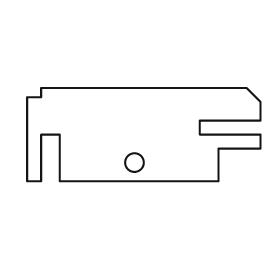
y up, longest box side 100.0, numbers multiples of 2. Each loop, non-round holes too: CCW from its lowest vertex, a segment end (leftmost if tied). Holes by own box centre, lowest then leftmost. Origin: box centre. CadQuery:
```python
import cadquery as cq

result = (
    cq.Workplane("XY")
    .moveTo(-50.0, -20.0)
    .lineTo(-44.0, -20.0)
    .lineTo(-44.0, 0.0)
    .lineTo(-36.0, 0.0)
    .lineTo(-36.0, -20.0)
    .lineTo(32.0, -20.0)
    .lineTo(32.0, -6.0)
    .lineTo(50.0, -6.0)
    .lineTo(50.0, 0.0)
    .lineTo(24.0, 0.0)
    .lineTo(24.0, 6.0)
    .lineTo(50.0, 6.0)
    .lineTo(50.0, 14.0)
    .lineTo(44.0, 20.0)
    .lineTo(-44.0, 20.0)
    .lineTo(-44.0, 16.0)
    .lineTo(-50.0, 16.0)
    .close()
    .moveTo(-4.0, -12.0)
    .circle(4.0)
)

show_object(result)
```